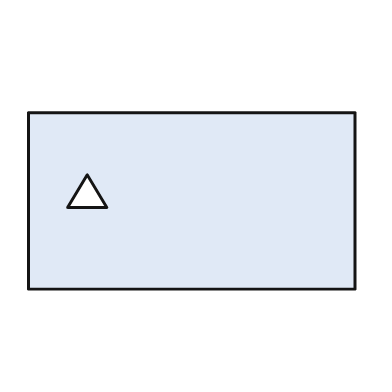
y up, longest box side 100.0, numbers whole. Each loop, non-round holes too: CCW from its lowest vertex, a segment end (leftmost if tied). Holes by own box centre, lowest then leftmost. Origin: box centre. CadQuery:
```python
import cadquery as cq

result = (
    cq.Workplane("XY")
    .moveTo(-50.0, -27.0)
    .lineTo(50.0, -27.0)
    .lineTo(50.0, 27.0)
    .lineTo(-50.0, 27.0)
    .close()
    .moveTo(-38.0, -2.0)
    .lineTo(-26.0, -2.0)
    .lineTo(-32.0, 8.0)
    .close()
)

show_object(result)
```